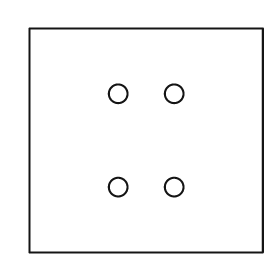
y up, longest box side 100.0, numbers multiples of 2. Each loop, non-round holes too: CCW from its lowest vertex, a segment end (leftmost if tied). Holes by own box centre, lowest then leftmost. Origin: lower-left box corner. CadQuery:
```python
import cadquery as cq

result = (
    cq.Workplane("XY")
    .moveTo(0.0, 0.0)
    .lineTo(100.0, 0.0)
    .lineTo(100.0, 96.0)
    .lineTo(0.0, 96.0)
    .close()
    .moveTo(38.0, 28.0)
    .circle(4.0)
    .moveTo(62.0, 28.0)
    .circle(4.0)
    .moveTo(38.0, 68.0)
    .circle(4.0)
    .moveTo(62.0, 68.0)
    .circle(4.0)
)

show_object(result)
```